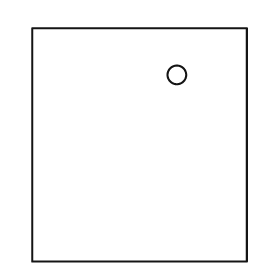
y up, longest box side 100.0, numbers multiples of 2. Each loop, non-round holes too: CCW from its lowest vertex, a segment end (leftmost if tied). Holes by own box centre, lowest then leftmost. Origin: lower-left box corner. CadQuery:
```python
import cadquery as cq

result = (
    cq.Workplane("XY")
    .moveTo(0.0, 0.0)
    .lineTo(92.0, 0.0)
    .lineTo(92.0, 100.0)
    .lineTo(0.0, 100.0)
    .close()
    .moveTo(62.0, 80.0)
    .circle(4.0)
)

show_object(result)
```